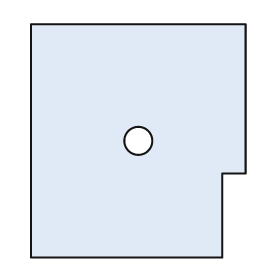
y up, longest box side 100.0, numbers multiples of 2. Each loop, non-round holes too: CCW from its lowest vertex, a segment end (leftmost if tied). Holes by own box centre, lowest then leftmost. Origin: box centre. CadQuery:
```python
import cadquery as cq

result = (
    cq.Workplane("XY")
    .moveTo(-46.0, -50.0)
    .lineTo(36.0, -50.0)
    .lineTo(36.0, -14.0)
    .lineTo(46.0, -14.0)
    .lineTo(46.0, 50.0)
    .lineTo(-46.0, 50.0)
    .close()
    .moveTo(0.0, 0.0)
    .circle(6.0)
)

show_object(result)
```